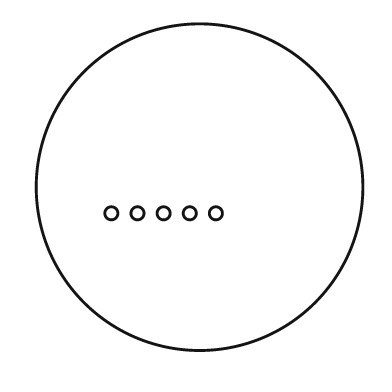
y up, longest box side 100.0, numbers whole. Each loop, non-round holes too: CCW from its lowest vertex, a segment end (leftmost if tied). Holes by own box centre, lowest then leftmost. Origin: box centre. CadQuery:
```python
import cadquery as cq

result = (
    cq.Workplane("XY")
    .moveTo(0.0, 0.0)
    .circle(50.0)
    .moveTo(-27.0, -8.0)
    .circle(2.0)
    .moveTo(-19.0, -8.0)
    .circle(2.0)
    .moveTo(-11.0, -8.0)
    .circle(2.0)
    .moveTo(-3.0, -8.0)
    .circle(2.0)
    .moveTo(5.0, -8.0)
    .circle(2.0)
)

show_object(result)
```